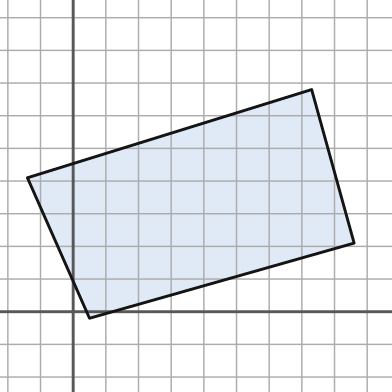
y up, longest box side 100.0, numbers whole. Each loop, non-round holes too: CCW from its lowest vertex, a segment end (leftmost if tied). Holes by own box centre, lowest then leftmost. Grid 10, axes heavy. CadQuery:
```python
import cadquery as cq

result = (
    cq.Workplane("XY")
    .moveTo(5.0, -2.0)
    .lineTo(86.0, 21.0)
    .lineTo(73.0, 68.0)
    .lineTo(-14.0, 41.0)
    .close()
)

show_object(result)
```